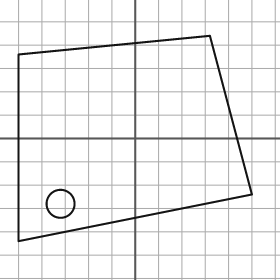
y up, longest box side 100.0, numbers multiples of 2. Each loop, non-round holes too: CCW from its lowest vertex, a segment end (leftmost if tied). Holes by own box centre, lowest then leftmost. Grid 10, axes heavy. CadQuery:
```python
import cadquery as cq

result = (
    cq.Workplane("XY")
    .moveTo(-50.0, -44.0)
    .lineTo(50.0, -24.0)
    .lineTo(32.0, 44.0)
    .lineTo(-50.0, 36.0)
    .close()
    .moveTo(-32.0, -28.0)
    .circle(6.0)
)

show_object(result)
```